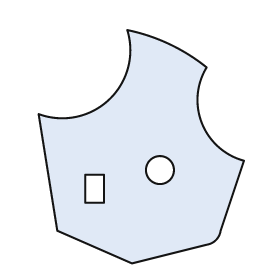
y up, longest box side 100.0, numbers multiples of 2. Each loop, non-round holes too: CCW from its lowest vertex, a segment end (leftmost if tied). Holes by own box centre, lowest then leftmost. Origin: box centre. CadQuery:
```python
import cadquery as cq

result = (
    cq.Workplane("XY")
    .moveTo(-4.0, -50.0)
    .lineTo(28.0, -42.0)
    .threePointArc((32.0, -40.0), (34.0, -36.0))
    .lineTo(44.0, -6.0)
    .threePointArc((26.0, 10.0), (28.0, 34.0))
    .threePointArc((12.0, 44.0), (-6.0, 50.0))
    .threePointArc((-14.0, 20.0), (-44.0, 14.0))
    .lineTo(-36.0, -36.0)
    .close()
    .moveTo(-24.0, -24.0)
    .lineTo(-16.0, -24.0)
    .lineTo(-16.0, -12.0)
    .lineTo(-24.0, -12.0)
    .close()
    .moveTo(8.0, -10.0)
    .circle(6.0)
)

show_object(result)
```